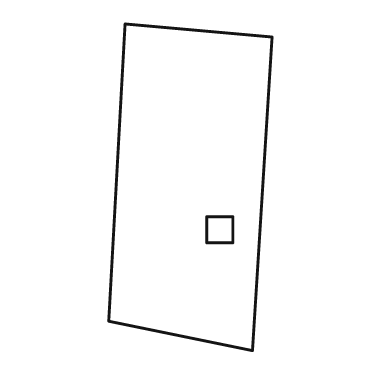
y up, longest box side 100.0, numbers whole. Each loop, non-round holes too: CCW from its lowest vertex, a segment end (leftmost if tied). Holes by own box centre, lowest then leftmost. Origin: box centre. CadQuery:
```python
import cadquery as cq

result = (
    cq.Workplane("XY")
    .moveTo(19.0, -50.0)
    .lineTo(25.0, 46.0)
    .lineTo(-20.0, 50.0)
    .lineTo(-25.0, -41.0)
    .close()
    .moveTo(5.0, -17.0)
    .lineTo(13.0, -17.0)
    .lineTo(13.0, -9.0)
    .lineTo(5.0, -9.0)
    .close()
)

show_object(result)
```